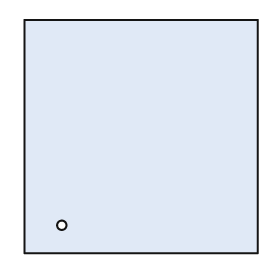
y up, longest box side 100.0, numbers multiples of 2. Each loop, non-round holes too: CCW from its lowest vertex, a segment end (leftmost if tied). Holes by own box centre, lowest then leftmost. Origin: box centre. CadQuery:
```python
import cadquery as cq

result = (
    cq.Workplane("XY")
    .moveTo(-50.0, -50.0)
    .lineTo(50.0, -50.0)
    .lineTo(50.0, 50.0)
    .lineTo(-50.0, 50.0)
    .close()
    .moveTo(-34.0, -38.0)
    .circle(2.0)
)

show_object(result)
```